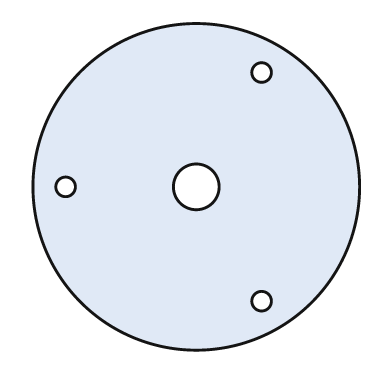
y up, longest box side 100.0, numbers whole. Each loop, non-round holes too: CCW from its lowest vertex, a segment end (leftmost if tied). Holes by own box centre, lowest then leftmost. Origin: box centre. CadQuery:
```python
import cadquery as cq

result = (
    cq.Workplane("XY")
    .moveTo(0.0, 0.0)
    .circle(50.0)
    .moveTo(20.0, -35.0)
    .circle(3.0)
    .moveTo(-40.0, 0.0)
    .circle(3.0)
    .moveTo(0.0, 0.0)
    .circle(7.0)
    .moveTo(20.0, 35.0)
    .circle(3.0)
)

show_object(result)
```